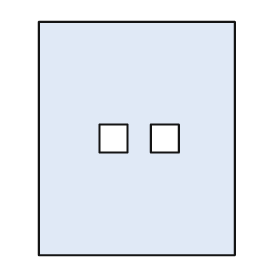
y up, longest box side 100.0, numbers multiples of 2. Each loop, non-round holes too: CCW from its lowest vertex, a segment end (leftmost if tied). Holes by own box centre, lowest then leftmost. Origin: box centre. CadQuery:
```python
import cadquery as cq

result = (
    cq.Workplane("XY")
    .moveTo(-42.0, -50.0)
    .lineTo(42.0, -50.0)
    .lineTo(42.0, 50.0)
    .lineTo(-42.0, 50.0)
    .close()
    .moveTo(-16.0, -6.0)
    .lineTo(-4.0, -6.0)
    .lineTo(-4.0, 6.0)
    .lineTo(-16.0, 6.0)
    .close()
    .moveTo(6.0, -6.0)
    .lineTo(18.0, -6.0)
    .lineTo(18.0, 6.0)
    .lineTo(6.0, 6.0)
    .close()
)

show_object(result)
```